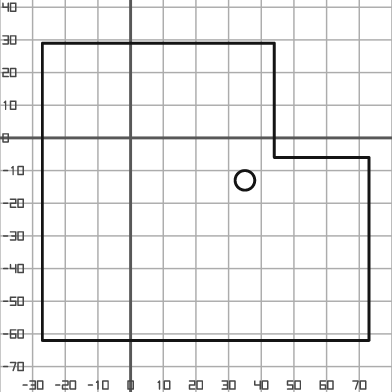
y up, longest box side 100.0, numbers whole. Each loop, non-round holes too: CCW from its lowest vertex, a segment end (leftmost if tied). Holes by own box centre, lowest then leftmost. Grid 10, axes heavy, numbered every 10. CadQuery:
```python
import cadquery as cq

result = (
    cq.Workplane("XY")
    .moveTo(-27.0, -62.0)
    .lineTo(73.0, -62.0)
    .lineTo(73.0, -6.0)
    .lineTo(44.0, -6.0)
    .lineTo(44.0, 29.0)
    .lineTo(-27.0, 29.0)
    .close()
    .moveTo(35.0, -13.0)
    .circle(3.0)
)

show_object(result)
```